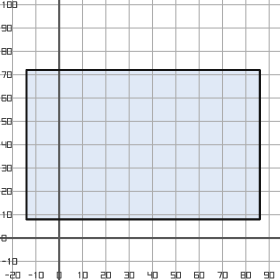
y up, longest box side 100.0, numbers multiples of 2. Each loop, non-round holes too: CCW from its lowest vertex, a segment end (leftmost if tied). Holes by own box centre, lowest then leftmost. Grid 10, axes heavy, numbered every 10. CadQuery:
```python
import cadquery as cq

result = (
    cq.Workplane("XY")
    .moveTo(-14.0, 8.0)
    .lineTo(86.0, 8.0)
    .lineTo(86.0, 72.0)
    .lineTo(-14.0, 72.0)
    .close()
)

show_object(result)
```